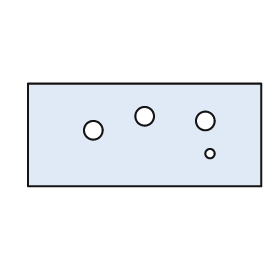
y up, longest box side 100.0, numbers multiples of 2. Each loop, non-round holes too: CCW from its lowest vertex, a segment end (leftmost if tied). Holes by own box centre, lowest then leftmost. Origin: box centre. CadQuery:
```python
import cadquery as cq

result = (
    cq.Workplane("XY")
    .moveTo(-50.0, -22.0)
    .lineTo(50.0, -22.0)
    .lineTo(50.0, 22.0)
    .lineTo(-50.0, 22.0)
    .close()
    .moveTo(28.0, -8.0)
    .circle(2.0)
    .moveTo(-22.0, 2.0)
    .circle(4.0)
    .moveTo(26.0, 6.0)
    .circle(4.0)
    .moveTo(0.0, 8.0)
    .circle(4.0)
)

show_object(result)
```